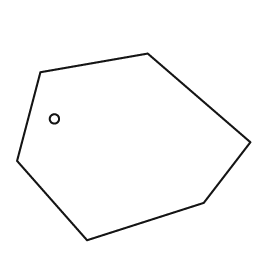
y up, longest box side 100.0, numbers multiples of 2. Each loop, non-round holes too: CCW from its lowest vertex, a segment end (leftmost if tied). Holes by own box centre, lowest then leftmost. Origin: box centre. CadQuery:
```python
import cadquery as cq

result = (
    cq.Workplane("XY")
    .moveTo(-20.0, -40.0)
    .lineTo(30.0, -24.0)
    .lineTo(50.0, 2.0)
    .lineTo(6.0, 40.0)
    .lineTo(-40.0, 32.0)
    .lineTo(-50.0, -6.0)
    .close()
    .moveTo(-34.0, 12.0)
    .circle(2.0)
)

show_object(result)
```